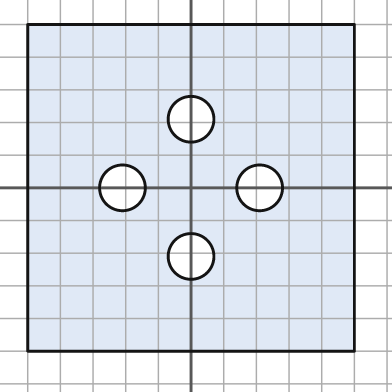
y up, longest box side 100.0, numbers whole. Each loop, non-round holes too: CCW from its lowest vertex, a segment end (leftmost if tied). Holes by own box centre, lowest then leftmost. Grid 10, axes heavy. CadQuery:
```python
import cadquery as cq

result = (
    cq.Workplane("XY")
    .moveTo(-50.0, -50.0)
    .lineTo(50.0, -50.0)
    .lineTo(50.0, 50.0)
    .lineTo(-50.0, 50.0)
    .close()
    .moveTo(0.0, -21.0)
    .circle(7.0)
    .moveTo(-21.0, 0.0)
    .circle(7.0)
    .moveTo(21.0, 0.0)
    .circle(7.0)
    .moveTo(0.0, 21.0)
    .circle(7.0)
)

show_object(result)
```